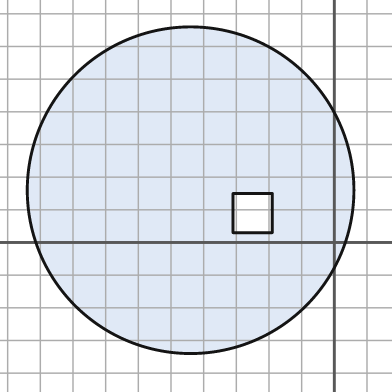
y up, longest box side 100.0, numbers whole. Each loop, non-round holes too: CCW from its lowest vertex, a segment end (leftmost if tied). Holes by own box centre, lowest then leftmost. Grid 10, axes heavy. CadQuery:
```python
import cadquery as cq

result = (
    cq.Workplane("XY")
    .moveTo(-44.0, 16.0)
    .circle(50.0)
    .moveTo(-31.0, 3.0)
    .lineTo(-19.0, 3.0)
    .lineTo(-19.0, 15.0)
    .lineTo(-31.0, 15.0)
    .close()
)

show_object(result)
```